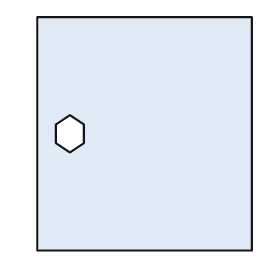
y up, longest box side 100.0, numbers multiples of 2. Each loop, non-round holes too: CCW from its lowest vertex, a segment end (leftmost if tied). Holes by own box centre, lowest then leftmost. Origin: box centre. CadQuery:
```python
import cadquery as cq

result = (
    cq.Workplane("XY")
    .moveTo(-46.0, -50.0)
    .lineTo(46.0, -50.0)
    .lineTo(46.0, 50.0)
    .lineTo(-46.0, 50.0)
    .close()
    .moveTo(-32.0, -8.0)
    .lineTo(-26.0, -4.0)
    .lineTo(-26.0, 4.0)
    .lineTo(-32.0, 8.0)
    .lineTo(-38.0, 4.0)
    .lineTo(-38.0, -4.0)
    .close()
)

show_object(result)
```